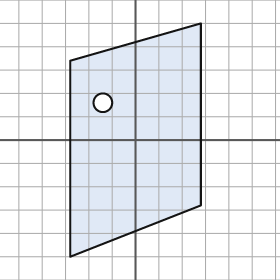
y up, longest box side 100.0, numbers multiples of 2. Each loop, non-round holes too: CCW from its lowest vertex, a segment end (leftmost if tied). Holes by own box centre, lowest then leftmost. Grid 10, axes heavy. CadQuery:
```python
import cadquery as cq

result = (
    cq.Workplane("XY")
    .moveTo(-28.0, -50.0)
    .lineTo(28.0, -28.0)
    .lineTo(28.0, 50.0)
    .lineTo(-28.0, 34.0)
    .close()
    .moveTo(-14.0, 16.0)
    .circle(4.0)
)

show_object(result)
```